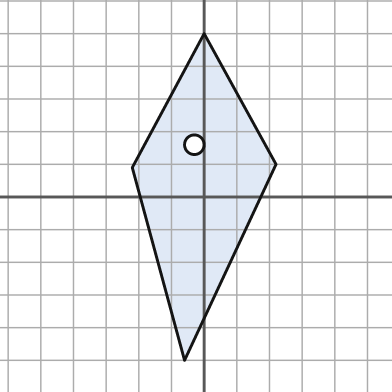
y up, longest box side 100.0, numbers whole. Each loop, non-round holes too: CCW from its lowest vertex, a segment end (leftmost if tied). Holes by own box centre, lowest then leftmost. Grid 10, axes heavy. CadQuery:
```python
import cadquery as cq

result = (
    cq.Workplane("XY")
    .moveTo(-6.0, -50.0)
    .lineTo(22.0, 10.0)
    .lineTo(0.0, 50.0)
    .lineTo(-22.0, 9.0)
    .close()
    .moveTo(-3.0, 16.0)
    .circle(3.0)
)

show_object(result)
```